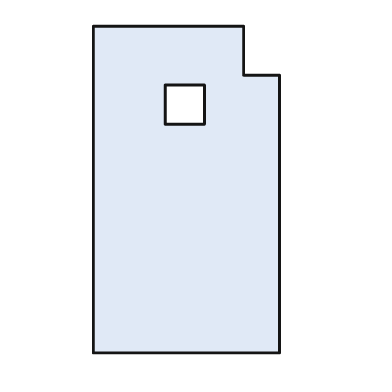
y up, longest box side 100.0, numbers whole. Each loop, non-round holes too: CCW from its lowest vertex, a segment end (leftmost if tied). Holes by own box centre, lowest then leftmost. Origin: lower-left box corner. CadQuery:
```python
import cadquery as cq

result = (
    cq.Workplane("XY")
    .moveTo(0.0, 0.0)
    .lineTo(57.0, 0.0)
    .lineTo(57.0, 85.0)
    .lineTo(46.0, 85.0)
    .lineTo(46.0, 100.0)
    .lineTo(0.0, 100.0)
    .close()
    .moveTo(22.0, 70.0)
    .lineTo(34.0, 70.0)
    .lineTo(34.0, 82.0)
    .lineTo(22.0, 82.0)
    .close()
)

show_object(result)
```